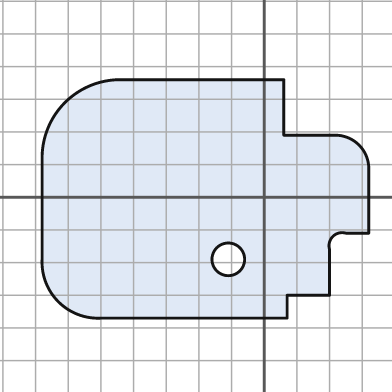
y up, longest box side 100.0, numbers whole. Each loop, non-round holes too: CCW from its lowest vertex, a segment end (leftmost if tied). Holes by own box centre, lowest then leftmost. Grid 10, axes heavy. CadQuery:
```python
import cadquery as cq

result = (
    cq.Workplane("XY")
    .moveTo(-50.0, -37.0)
    .lineTo(7.0, -37.0)
    .lineTo(7.0, -30.0)
    .lineTo(20.0, -30.0)
    .lineTo(20.0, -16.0)
    .threePointArc((21.0, -12.0), (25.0, -11.0))
    .lineTo(32.0, -11.0)
    .lineTo(32.0, 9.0)
    .threePointArc((29.0, 16.0), (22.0, 19.0))
    .lineTo(6.0, 19.0)
    .lineTo(6.0, 36.0)
    .lineTo(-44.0, 36.0)
    .threePointArc((-61.0, 29.0), (-68.0, 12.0))
    .lineTo(-68.0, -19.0)
    .threePointArc((-63.0, -32.0), (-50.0, -37.0))
    .close()
    .moveTo(-11.0, -19.0)
    .circle(5.0)
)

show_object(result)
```